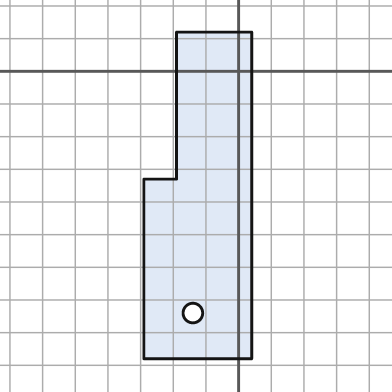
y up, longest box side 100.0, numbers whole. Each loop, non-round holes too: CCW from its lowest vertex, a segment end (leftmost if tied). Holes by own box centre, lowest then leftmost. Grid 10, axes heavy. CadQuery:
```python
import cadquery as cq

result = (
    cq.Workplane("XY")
    .moveTo(-29.0, -88.0)
    .lineTo(4.0, -88.0)
    .lineTo(4.0, 12.0)
    .lineTo(-19.0, 12.0)
    .lineTo(-19.0, -33.0)
    .lineTo(-29.0, -33.0)
    .close()
    .moveTo(-14.0, -74.0)
    .circle(3.0)
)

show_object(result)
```